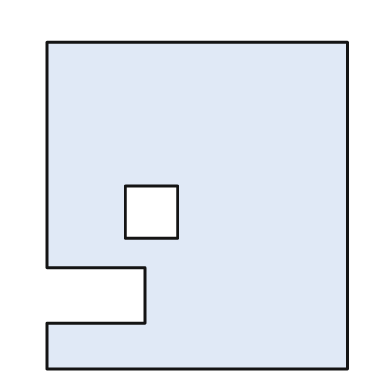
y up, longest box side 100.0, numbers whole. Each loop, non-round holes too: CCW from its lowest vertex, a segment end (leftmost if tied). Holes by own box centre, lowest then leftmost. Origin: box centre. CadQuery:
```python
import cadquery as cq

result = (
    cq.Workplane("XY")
    .moveTo(-46.0, -50.0)
    .lineTo(46.0, -50.0)
    .lineTo(46.0, 50.0)
    .lineTo(-46.0, 50.0)
    .lineTo(-46.0, -19.0)
    .lineTo(-16.0, -19.0)
    .lineTo(-16.0, -36.0)
    .lineTo(-46.0, -36.0)
    .close()
    .moveTo(-22.0, -10.0)
    .lineTo(-6.0, -10.0)
    .lineTo(-6.0, 6.0)
    .lineTo(-22.0, 6.0)
    .close()
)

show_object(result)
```